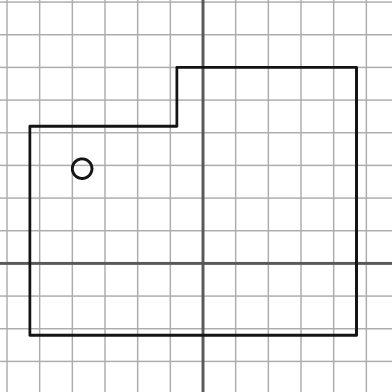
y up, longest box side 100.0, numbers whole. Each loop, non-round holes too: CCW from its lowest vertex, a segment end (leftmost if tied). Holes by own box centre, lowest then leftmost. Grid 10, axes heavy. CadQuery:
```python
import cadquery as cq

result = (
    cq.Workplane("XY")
    .moveTo(-53.0, -22.0)
    .lineTo(47.0, -22.0)
    .lineTo(47.0, 60.0)
    .lineTo(-8.0, 60.0)
    .lineTo(-8.0, 42.0)
    .lineTo(-53.0, 42.0)
    .close()
    .moveTo(-37.0, 29.0)
    .circle(3.0)
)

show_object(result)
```